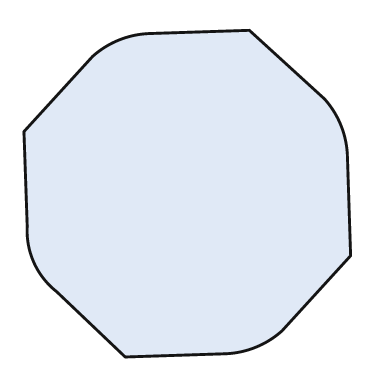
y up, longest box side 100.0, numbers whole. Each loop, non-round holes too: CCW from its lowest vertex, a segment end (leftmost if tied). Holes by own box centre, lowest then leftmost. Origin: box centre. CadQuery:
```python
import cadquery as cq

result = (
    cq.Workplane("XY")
    .moveTo(-19.0, -50.0)
    .lineTo(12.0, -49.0)
    .threePointArc((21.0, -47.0), (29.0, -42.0))
    .lineTo(50.0, -19.0)
    .lineTo(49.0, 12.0)
    .threePointArc((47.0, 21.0), (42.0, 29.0))
    .lineTo(19.0, 50.0)
    .lineTo(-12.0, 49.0)
    .threePointArc((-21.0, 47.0), (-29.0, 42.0))
    .lineTo(-50.0, 19.0)
    .lineTo(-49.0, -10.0)
    .threePointArc((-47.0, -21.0), (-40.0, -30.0))
    .close()
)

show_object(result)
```